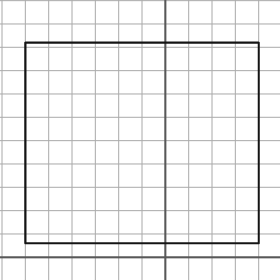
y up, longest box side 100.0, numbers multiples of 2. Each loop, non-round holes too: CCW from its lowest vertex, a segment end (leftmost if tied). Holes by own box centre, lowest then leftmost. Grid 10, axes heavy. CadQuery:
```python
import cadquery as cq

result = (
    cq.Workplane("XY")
    .moveTo(-60.0, 6.0)
    .lineTo(40.0, 6.0)
    .lineTo(40.0, 92.0)
    .lineTo(-60.0, 92.0)
    .close()
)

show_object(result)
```